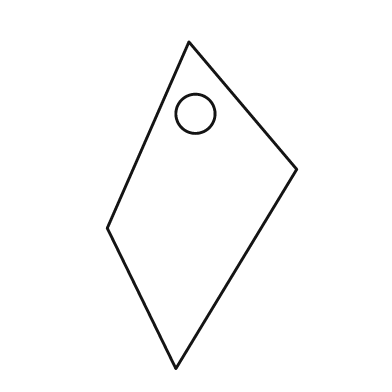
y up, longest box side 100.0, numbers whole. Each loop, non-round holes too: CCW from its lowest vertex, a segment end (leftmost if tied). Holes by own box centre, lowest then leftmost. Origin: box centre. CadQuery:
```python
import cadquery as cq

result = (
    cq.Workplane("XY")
    .moveTo(-8.0, -50.0)
    .lineTo(29.0, 11.0)
    .lineTo(-4.0, 50.0)
    .lineTo(-29.0, -7.0)
    .close()
    .moveTo(-2.0, 28.0)
    .circle(6.0)
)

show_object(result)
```